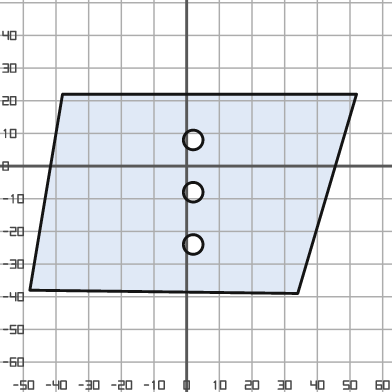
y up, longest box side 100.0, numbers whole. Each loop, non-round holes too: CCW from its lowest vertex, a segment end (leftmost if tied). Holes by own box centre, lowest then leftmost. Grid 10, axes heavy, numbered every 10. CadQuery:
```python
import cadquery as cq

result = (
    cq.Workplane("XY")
    .moveTo(34.0, -39.0)
    .lineTo(52.0, 22.0)
    .lineTo(-38.0, 22.0)
    .lineTo(-48.0, -38.0)
    .close()
    .moveTo(2.0, -24.0)
    .circle(3.0)
    .moveTo(2.0, -8.0)
    .circle(3.0)
    .moveTo(2.0, 8.0)
    .circle(3.0)
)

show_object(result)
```